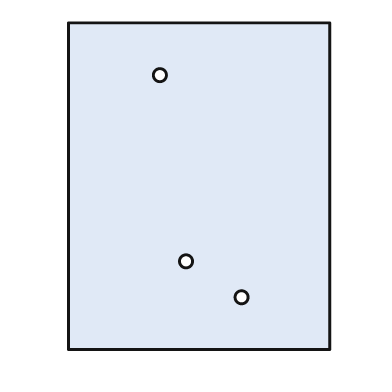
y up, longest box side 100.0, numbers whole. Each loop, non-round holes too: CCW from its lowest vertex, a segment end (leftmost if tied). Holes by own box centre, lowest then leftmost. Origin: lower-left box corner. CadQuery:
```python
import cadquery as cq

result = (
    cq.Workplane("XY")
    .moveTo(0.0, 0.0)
    .lineTo(80.0, 0.0)
    .lineTo(80.0, 100.0)
    .lineTo(0.0, 100.0)
    .close()
    .moveTo(53.0, 16.0)
    .circle(2.0)
    .moveTo(36.0, 27.0)
    .circle(2.0)
    .moveTo(28.0, 84.0)
    .circle(2.0)
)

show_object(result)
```